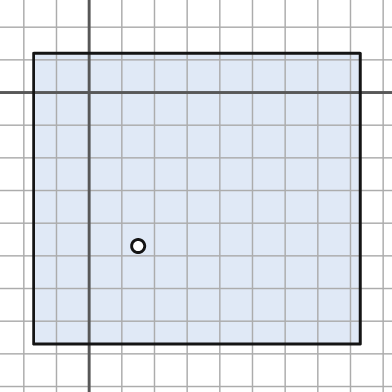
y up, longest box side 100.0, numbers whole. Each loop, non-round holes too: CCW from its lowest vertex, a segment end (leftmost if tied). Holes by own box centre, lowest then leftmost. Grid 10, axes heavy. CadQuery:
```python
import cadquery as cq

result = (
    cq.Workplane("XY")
    .moveTo(-17.0, -77.0)
    .lineTo(83.0, -77.0)
    .lineTo(83.0, 12.0)
    .lineTo(-17.0, 12.0)
    .close()
    .moveTo(15.0, -47.0)
    .circle(2.0)
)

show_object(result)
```